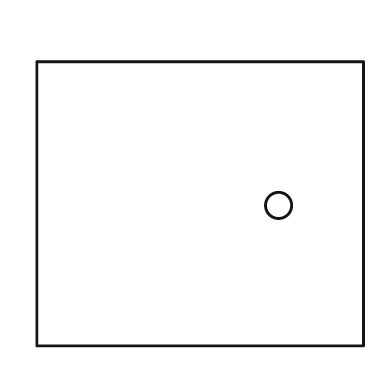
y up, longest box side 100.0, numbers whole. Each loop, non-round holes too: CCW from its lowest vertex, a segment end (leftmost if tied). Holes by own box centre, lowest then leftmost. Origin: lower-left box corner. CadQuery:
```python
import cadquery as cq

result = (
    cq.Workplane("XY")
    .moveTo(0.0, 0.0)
    .lineTo(100.0, 0.0)
    .lineTo(100.0, 87.0)
    .lineTo(0.0, 87.0)
    .close()
    .moveTo(74.0, 43.0)
    .circle(4.0)
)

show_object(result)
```